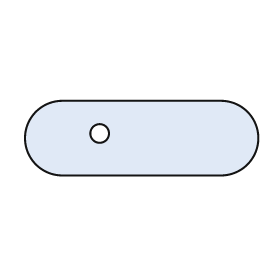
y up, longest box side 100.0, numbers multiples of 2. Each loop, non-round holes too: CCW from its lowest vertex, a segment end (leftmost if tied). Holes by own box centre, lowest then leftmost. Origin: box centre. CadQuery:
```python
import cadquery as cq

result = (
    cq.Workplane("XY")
    .moveTo(-34.0, -16.0)
    .lineTo(34.0, -16.0)
    .threePointArc((50.0, 0.0), (34.0, 16.0))
    .lineTo(-34.0, 16.0)
    .threePointArc((-50.0, 0.0), (-34.0, -16.0))
    .close()
    .moveTo(-18.0, 2.0)
    .circle(4.0)
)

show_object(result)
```